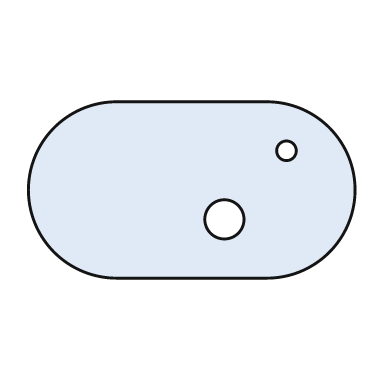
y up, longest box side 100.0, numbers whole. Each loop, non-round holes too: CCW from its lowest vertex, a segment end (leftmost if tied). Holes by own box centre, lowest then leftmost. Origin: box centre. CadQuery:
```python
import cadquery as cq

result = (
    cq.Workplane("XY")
    .moveTo(-23.0, -27.0)
    .lineTo(23.0, -27.0)
    .threePointArc((50.0, 0.0), (23.0, 27.0))
    .lineTo(-23.0, 27.0)
    .threePointArc((-50.0, 0.0), (-23.0, -27.0))
    .close()
    .moveTo(10.0, -9.0)
    .circle(6.0)
    .moveTo(29.0, 12.0)
    .circle(3.0)
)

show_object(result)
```